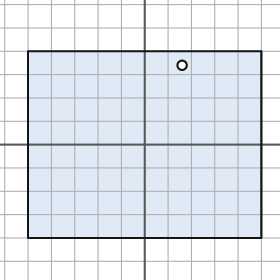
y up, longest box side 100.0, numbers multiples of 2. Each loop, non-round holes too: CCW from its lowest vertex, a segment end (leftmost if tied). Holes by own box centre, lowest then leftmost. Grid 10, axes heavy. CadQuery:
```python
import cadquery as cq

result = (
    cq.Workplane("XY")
    .moveTo(-50.0, -40.0)
    .lineTo(50.0, -40.0)
    .lineTo(50.0, 40.0)
    .lineTo(-50.0, 40.0)
    .close()
    .moveTo(16.0, 34.0)
    .circle(2.0)
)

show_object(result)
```